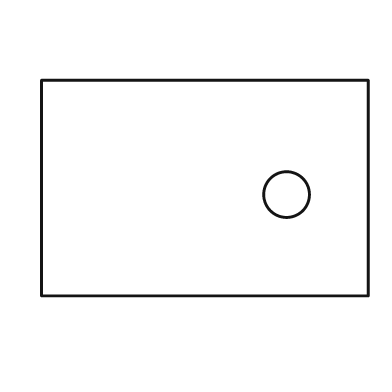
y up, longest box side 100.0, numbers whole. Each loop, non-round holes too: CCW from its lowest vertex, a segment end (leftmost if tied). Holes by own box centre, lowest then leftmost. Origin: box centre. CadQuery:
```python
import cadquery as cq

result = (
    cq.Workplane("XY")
    .moveTo(-50.0, -33.0)
    .lineTo(50.0, -33.0)
    .lineTo(50.0, 33.0)
    .lineTo(-50.0, 33.0)
    .close()
    .moveTo(25.0, -2.0)
    .circle(7.0)
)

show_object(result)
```